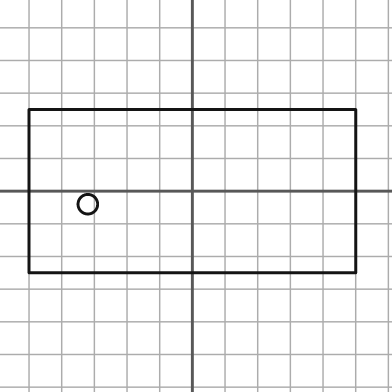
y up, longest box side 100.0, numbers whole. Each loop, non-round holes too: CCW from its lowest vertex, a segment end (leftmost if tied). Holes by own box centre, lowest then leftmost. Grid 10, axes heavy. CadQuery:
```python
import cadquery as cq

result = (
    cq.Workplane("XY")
    .moveTo(-50.0, -25.0)
    .lineTo(50.0, -25.0)
    .lineTo(50.0, 25.0)
    .lineTo(-50.0, 25.0)
    .close()
    .moveTo(-32.0, -4.0)
    .circle(3.0)
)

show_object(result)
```